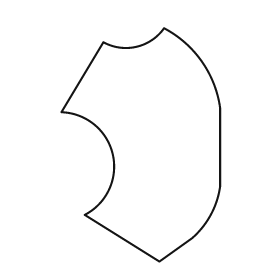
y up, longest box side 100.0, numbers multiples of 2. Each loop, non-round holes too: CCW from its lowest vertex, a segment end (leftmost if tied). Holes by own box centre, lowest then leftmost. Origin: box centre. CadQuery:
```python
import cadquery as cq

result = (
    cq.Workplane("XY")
    .moveTo(8.0, -50.0)
    .lineTo(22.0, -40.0)
    .threePointArc((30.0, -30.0), (34.0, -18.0))
    .lineTo(34.0, 16.0)
    .threePointArc((26.0, 36.0), (10.0, 50.0))
    .threePointArc((-2.0, 42.0), (-16.0, 44.0))
    .lineTo(-34.0, 14.0)
    .threePointArc((-12.0, -4.0), (-24.0, -30.0))
    .close()
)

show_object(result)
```